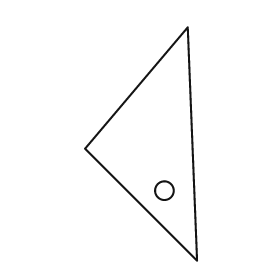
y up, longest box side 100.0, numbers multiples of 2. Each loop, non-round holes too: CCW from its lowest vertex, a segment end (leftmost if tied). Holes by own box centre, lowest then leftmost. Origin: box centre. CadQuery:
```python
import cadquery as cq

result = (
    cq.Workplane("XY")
    .moveTo(24.0, -50.0)
    .lineTo(20.0, 50.0)
    .lineTo(-24.0, -2.0)
    .close()
    .moveTo(10.0, -20.0)
    .circle(4.0)
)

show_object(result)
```